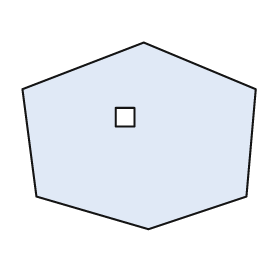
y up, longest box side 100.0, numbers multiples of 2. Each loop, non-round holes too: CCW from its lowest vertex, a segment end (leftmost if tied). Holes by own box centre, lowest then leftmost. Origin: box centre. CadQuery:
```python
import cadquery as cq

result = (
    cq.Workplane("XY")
    .moveTo(4.0, -40.0)
    .lineTo(46.0, -26.0)
    .lineTo(50.0, 20.0)
    .lineTo(2.0, 40.0)
    .lineTo(-50.0, 20.0)
    .lineTo(-44.0, -26.0)
    .close()
    .moveTo(-10.0, 4.0)
    .lineTo(-2.0, 4.0)
    .lineTo(-2.0, 12.0)
    .lineTo(-10.0, 12.0)
    .close()
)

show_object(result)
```